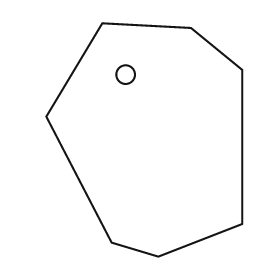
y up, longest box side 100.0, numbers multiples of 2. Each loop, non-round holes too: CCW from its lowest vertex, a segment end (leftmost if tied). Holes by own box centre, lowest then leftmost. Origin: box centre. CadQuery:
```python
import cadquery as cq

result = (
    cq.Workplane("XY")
    .moveTo(6.0, -50.0)
    .lineTo(42.0, -36.0)
    .lineTo(42.0, 30.0)
    .lineTo(20.0, 48.0)
    .lineTo(-18.0, 50.0)
    .lineTo(-42.0, 10.0)
    .lineTo(-14.0, -44.0)
    .close()
    .moveTo(-8.0, 28.0)
    .circle(4.0)
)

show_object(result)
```